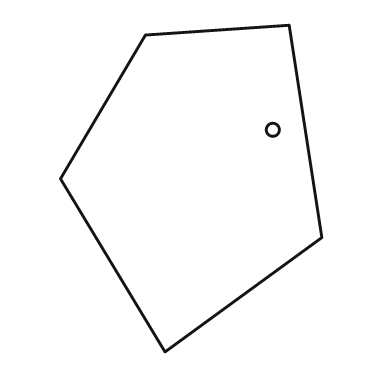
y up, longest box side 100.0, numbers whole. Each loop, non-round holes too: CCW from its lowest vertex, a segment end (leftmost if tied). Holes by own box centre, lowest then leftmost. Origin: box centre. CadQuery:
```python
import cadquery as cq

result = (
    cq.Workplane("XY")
    .moveTo(-8.0, -50.0)
    .lineTo(40.0, -15.0)
    .lineTo(30.0, 50.0)
    .lineTo(-14.0, 47.0)
    .lineTo(-40.0, 3.0)
    .close()
    .moveTo(25.0, 18.0)
    .circle(2.0)
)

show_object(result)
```